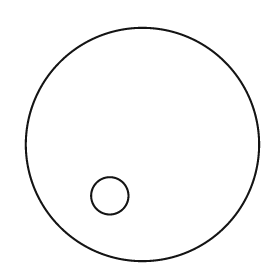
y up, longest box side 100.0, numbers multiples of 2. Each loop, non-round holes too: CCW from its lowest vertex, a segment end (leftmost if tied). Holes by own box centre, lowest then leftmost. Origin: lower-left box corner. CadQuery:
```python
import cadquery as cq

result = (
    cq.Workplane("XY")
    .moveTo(50.0, 50.0)
    .circle(50.0)
    .moveTo(36.0, 28.0)
    .circle(8.0)
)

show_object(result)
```